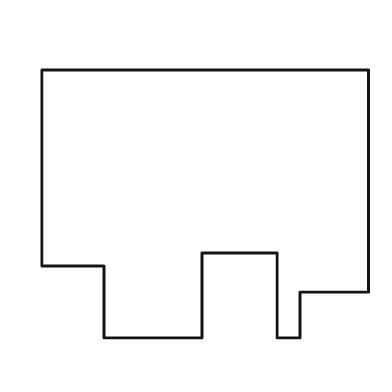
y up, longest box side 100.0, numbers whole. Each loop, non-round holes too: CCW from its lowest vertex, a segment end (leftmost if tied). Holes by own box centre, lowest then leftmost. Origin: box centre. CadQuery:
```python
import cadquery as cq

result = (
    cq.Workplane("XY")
    .moveTo(-31.0, -41.0)
    .lineTo(-1.0, -41.0)
    .lineTo(-1.0, -15.0)
    .lineTo(22.0, -15.0)
    .lineTo(22.0, -41.0)
    .lineTo(29.0, -41.0)
    .lineTo(29.0, -27.0)
    .lineTo(50.0, -27.0)
    .lineTo(50.0, 41.0)
    .lineTo(-50.0, 41.0)
    .lineTo(-50.0, -19.0)
    .lineTo(-31.0, -19.0)
    .close()
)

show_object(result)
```